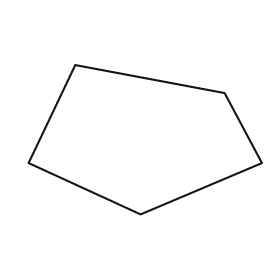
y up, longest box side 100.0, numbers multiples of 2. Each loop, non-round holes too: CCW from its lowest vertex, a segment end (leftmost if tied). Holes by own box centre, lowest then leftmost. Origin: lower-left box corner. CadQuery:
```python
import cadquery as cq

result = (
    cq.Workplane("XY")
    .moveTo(48.0, 0.0)
    .lineTo(100.0, 22.0)
    .lineTo(84.0, 52.0)
    .lineTo(20.0, 64.0)
    .lineTo(0.0, 22.0)
    .close()
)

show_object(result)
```